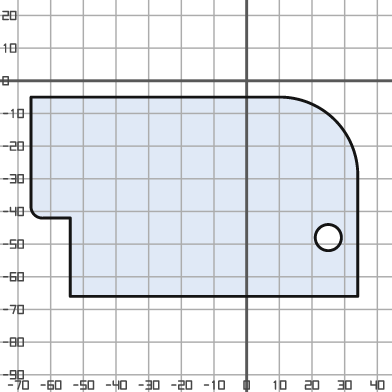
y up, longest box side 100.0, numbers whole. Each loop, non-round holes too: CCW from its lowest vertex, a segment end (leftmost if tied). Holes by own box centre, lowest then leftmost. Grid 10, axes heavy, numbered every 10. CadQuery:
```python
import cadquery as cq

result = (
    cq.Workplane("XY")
    .moveTo(-54.0, -66.0)
    .lineTo(34.0, -66.0)
    .lineTo(34.0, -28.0)
    .threePointArc((27.0, -12.0), (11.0, -5.0))
    .lineTo(-66.0, -5.0)
    .lineTo(-66.0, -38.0)
    .threePointArc((-65.0, -41.0), (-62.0, -42.0))
    .lineTo(-54.0, -42.0)
    .close()
    .moveTo(25.0, -48.0)
    .circle(4.0)
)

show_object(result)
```